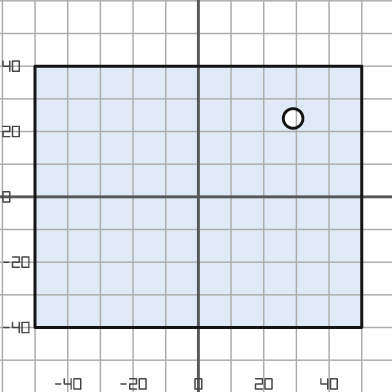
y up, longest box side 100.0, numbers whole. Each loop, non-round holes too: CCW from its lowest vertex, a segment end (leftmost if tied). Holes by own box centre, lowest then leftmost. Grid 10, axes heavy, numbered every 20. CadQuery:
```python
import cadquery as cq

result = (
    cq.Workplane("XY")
    .moveTo(-50.0, -40.0)
    .lineTo(50.0, -40.0)
    .lineTo(50.0, 40.0)
    .lineTo(-50.0, 40.0)
    .close()
    .moveTo(29.0, 24.0)
    .circle(3.0)
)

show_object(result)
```